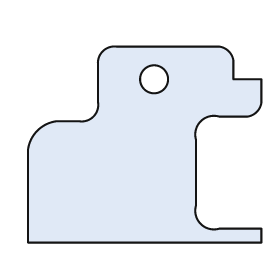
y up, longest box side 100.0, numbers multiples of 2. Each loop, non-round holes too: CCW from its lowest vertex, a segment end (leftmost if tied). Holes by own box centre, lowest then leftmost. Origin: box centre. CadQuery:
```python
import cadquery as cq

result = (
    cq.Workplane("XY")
    .moveTo(-50.0, -42.0)
    .lineTo(50.0, -42.0)
    .lineTo(50.0, -36.0)
    .lineTo(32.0, -36.0)
    .threePointArc((24.0, -34.0), (22.0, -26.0))
    .lineTo(22.0, 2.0)
    .threePointArc((24.0, 10.0), (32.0, 12.0))
    .lineTo(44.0, 12.0)
    .threePointArc((48.0, 14.0), (50.0, 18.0))
    .lineTo(50.0, 28.0)
    .lineTo(38.0, 28.0)
    .lineTo(38.0, 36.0)
    .threePointArc((36.0, 40.0), (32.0, 42.0))
    .lineTo(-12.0, 42.0)
    .threePointArc((-18.0, 40.0), (-20.0, 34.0))
    .lineTo(-20.0, 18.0)
    .threePointArc((-22.0, 12.0), (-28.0, 10.0))
    .lineTo(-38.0, 10.0)
    .threePointArc((-46.0, 6.0), (-50.0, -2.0))
    .close()
    .moveTo(4.0, 28.0)
    .circle(6.0)
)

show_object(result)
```